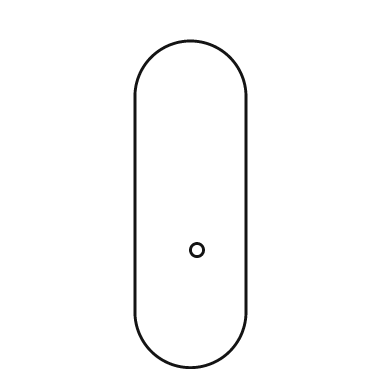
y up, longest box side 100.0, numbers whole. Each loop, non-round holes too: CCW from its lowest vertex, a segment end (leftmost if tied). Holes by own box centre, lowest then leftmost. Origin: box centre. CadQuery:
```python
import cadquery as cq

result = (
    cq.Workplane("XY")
    .moveTo(-17.0, -33.0)
    .threePointArc((0.0, -50.0), (17.0, -33.0))
    .lineTo(17.0, 33.0)
    .threePointArc((0.0, 50.0), (-17.0, 33.0))
    .close()
    .moveTo(2.0, -14.0)
    .circle(2.0)
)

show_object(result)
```